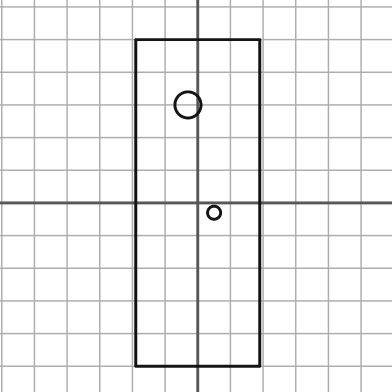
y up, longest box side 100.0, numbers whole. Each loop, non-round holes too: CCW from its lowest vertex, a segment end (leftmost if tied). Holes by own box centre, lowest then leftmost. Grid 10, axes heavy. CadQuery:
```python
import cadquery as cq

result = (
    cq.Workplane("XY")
    .moveTo(-19.0, -50.0)
    .lineTo(19.0, -50.0)
    .lineTo(19.0, 50.0)
    .lineTo(-19.0, 50.0)
    .close()
    .moveTo(5.0, -3.0)
    .circle(2.0)
    .moveTo(-3.0, 30.0)
    .circle(4.0)
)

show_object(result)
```